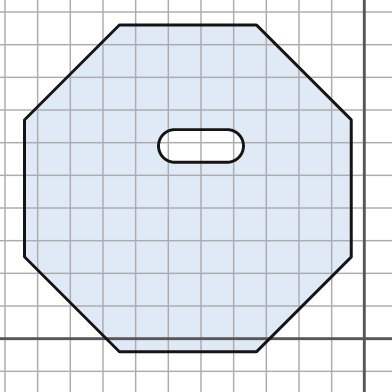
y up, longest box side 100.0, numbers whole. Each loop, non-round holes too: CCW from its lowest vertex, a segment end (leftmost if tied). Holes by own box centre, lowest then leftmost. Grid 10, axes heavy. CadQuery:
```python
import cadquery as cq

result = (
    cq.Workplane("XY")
    .moveTo(-75.0, -4.0)
    .lineTo(-33.0, -4.0)
    .lineTo(-4.0, 25.0)
    .lineTo(-4.0, 67.0)
    .lineTo(-33.0, 96.0)
    .lineTo(-75.0, 96.0)
    .lineTo(-104.0, 67.0)
    .lineTo(-104.0, 25.0)
    .close()
    .moveTo(-58.0, 54.0)
    .lineTo(-42.0, 54.0)
    .threePointArc((-37.0, 59.0), (-42.0, 64.0))
    .lineTo(-58.0, 64.0)
    .threePointArc((-63.0, 59.0), (-58.0, 54.0))
    .close()
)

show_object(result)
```